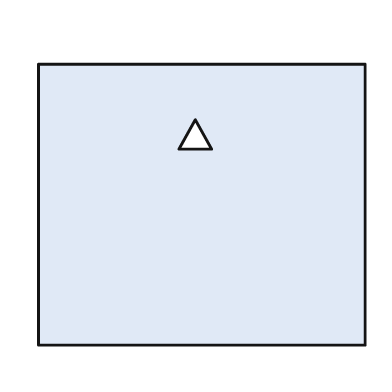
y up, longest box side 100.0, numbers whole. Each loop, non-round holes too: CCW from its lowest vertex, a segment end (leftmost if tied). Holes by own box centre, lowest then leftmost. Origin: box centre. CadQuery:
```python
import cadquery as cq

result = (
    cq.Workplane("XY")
    .moveTo(-50.0, -43.0)
    .lineTo(50.0, -43.0)
    .lineTo(50.0, 43.0)
    .lineTo(-50.0, 43.0)
    .close()
    .moveTo(-7.0, 17.0)
    .lineTo(3.0, 17.0)
    .lineTo(-2.0, 26.0)
    .close()
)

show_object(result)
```